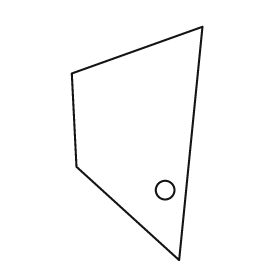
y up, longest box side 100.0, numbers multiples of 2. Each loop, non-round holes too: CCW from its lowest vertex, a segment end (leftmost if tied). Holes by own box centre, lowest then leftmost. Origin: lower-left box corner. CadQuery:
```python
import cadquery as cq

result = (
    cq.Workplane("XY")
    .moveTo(46.0, 0.0)
    .lineTo(56.0, 100.0)
    .lineTo(0.0, 80.0)
    .lineTo(2.0, 40.0)
    .close()
    .moveTo(40.0, 30.0)
    .circle(4.0)
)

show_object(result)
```